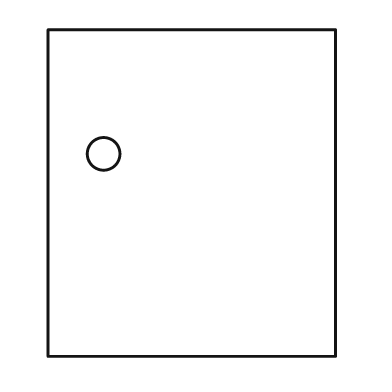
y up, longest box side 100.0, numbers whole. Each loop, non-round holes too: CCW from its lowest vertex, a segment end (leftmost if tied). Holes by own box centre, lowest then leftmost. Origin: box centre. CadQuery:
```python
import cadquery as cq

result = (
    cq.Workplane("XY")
    .moveTo(-44.0, -50.0)
    .lineTo(44.0, -50.0)
    .lineTo(44.0, 50.0)
    .lineTo(-44.0, 50.0)
    .close()
    .moveTo(-27.0, 12.0)
    .circle(5.0)
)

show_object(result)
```